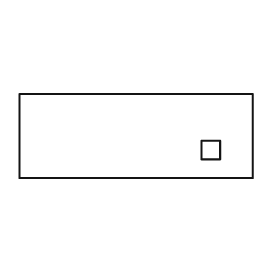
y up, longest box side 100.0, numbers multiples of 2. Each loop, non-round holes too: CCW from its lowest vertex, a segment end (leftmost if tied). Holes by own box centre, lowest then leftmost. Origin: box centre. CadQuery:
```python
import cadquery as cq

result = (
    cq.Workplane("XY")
    .moveTo(-50.0, -18.0)
    .lineTo(50.0, -18.0)
    .lineTo(50.0, 18.0)
    .lineTo(-50.0, 18.0)
    .close()
    .moveTo(28.0, -10.0)
    .lineTo(36.0, -10.0)
    .lineTo(36.0, -2.0)
    .lineTo(28.0, -2.0)
    .close()
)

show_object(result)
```